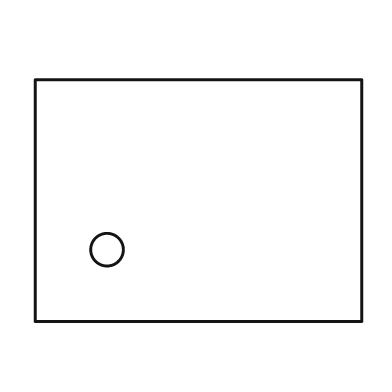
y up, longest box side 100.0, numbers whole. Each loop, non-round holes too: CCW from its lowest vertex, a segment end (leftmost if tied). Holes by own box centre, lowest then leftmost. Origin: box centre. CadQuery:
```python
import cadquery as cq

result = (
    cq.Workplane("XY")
    .moveTo(-50.0, -37.0)
    .lineTo(50.0, -37.0)
    .lineTo(50.0, 37.0)
    .lineTo(-50.0, 37.0)
    .close()
    .moveTo(-28.0, -15.0)
    .circle(5.0)
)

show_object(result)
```